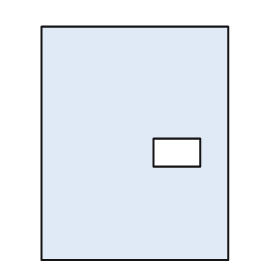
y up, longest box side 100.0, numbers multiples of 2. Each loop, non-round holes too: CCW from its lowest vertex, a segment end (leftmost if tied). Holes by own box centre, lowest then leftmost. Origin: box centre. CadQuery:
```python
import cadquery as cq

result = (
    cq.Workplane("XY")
    .moveTo(-40.0, -50.0)
    .lineTo(40.0, -50.0)
    .lineTo(40.0, 50.0)
    .lineTo(-40.0, 50.0)
    .close()
    .moveTo(8.0, -10.0)
    .lineTo(28.0, -10.0)
    .lineTo(28.0, 2.0)
    .lineTo(8.0, 2.0)
    .close()
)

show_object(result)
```